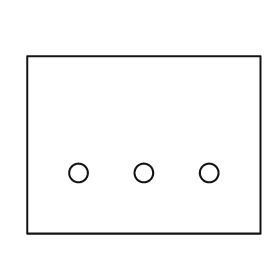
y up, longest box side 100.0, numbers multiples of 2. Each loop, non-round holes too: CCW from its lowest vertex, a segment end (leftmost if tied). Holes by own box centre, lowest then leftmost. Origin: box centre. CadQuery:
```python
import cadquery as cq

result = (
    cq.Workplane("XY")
    .moveTo(-50.0, -38.0)
    .lineTo(50.0, -38.0)
    .lineTo(50.0, 38.0)
    .lineTo(-50.0, 38.0)
    .close()
    .moveTo(-28.0, -12.0)
    .circle(4.0)
    .moveTo(0.0, -12.0)
    .circle(4.0)
    .moveTo(28.0, -12.0)
    .circle(4.0)
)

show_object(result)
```